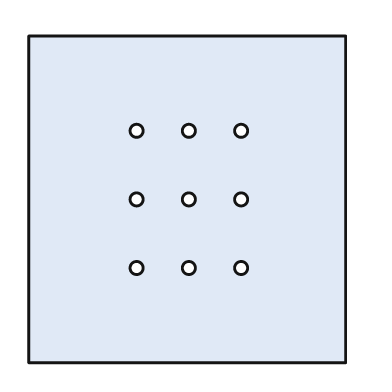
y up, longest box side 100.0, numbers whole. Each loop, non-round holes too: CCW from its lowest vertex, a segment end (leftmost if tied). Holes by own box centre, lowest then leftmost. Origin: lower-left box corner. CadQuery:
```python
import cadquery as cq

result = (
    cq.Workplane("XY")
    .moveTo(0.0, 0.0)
    .lineTo(97.0, 0.0)
    .lineTo(97.0, 100.0)
    .lineTo(0.0, 100.0)
    .close()
    .moveTo(33.0, 29.0)
    .circle(2.0)
    .moveTo(49.0, 29.0)
    .circle(2.0)
    .moveTo(65.0, 29.0)
    .circle(2.0)
    .moveTo(33.0, 50.0)
    .circle(2.0)
    .moveTo(49.0, 50.0)
    .circle(2.0)
    .moveTo(65.0, 50.0)
    .circle(2.0)
    .moveTo(33.0, 71.0)
    .circle(2.0)
    .moveTo(49.0, 71.0)
    .circle(2.0)
    .moveTo(65.0, 71.0)
    .circle(2.0)
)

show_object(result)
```